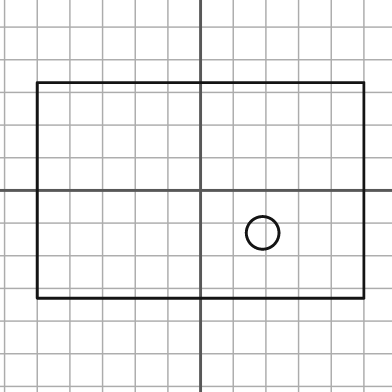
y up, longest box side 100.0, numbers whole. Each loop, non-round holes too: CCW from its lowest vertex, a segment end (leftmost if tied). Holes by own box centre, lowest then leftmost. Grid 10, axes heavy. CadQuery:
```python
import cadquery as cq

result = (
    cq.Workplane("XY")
    .moveTo(-50.0, -33.0)
    .lineTo(50.0, -33.0)
    .lineTo(50.0, 33.0)
    .lineTo(-50.0, 33.0)
    .close()
    .moveTo(19.0, -13.0)
    .circle(5.0)
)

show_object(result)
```